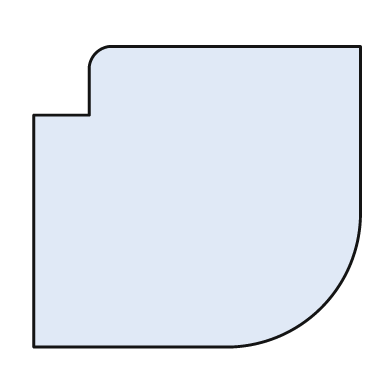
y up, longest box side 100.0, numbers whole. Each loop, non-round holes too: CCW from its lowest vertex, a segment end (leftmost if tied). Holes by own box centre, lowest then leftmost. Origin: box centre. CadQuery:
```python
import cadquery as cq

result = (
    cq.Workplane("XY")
    .moveTo(-50.0, -46.0)
    .lineTo(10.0, -46.0)
    .threePointArc((38.0, -34.0), (50.0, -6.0))
    .lineTo(50.0, 46.0)
    .lineTo(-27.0, 46.0)
    .threePointArc((-31.0, 44.0), (-33.0, 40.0))
    .lineTo(-33.0, 25.0)
    .lineTo(-50.0, 25.0)
    .close()
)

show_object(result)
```